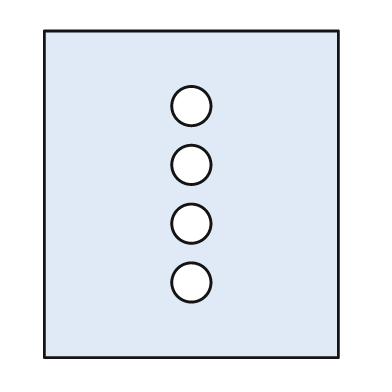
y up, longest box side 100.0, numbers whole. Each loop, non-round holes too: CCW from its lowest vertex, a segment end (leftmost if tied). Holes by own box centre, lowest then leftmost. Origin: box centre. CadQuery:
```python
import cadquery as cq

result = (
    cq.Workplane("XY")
    .moveTo(-45.0, -50.0)
    .lineTo(45.0, -50.0)
    .lineTo(45.0, 50.0)
    .lineTo(-45.0, 50.0)
    .close()
    .moveTo(0.0, -27.0)
    .circle(6.0)
    .moveTo(0.0, -9.0)
    .circle(6.0)
    .moveTo(0.0, 9.0)
    .circle(6.0)
    .moveTo(0.0, 27.0)
    .circle(6.0)
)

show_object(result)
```